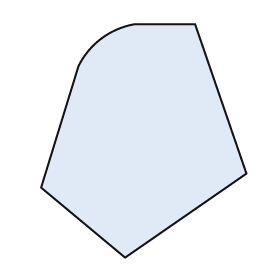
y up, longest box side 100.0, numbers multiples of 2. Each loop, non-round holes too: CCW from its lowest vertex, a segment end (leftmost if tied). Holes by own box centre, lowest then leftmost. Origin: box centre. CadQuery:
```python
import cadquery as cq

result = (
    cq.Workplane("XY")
    .moveTo(-8.0, -50.0)
    .lineTo(44.0, -14.0)
    .lineTo(22.0, 50.0)
    .lineTo(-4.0, 50.0)
    .threePointArc((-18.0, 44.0), (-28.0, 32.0))
    .lineTo(-44.0, -20.0)
    .close()
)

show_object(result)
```